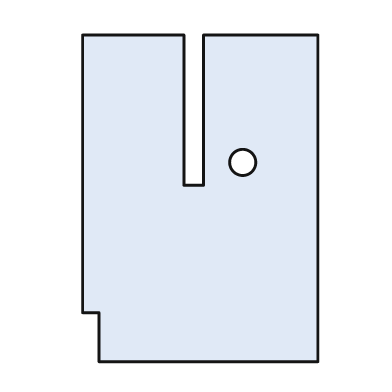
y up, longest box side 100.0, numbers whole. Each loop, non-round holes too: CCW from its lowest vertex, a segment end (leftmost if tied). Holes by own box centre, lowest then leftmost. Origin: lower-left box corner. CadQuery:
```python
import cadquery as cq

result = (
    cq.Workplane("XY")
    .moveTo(5.0, 0.0)
    .lineTo(72.0, 0.0)
    .lineTo(72.0, 100.0)
    .lineTo(37.0, 100.0)
    .lineTo(37.0, 54.0)
    .lineTo(31.0, 54.0)
    .lineTo(31.0, 100.0)
    .lineTo(0.0, 100.0)
    .lineTo(0.0, 15.0)
    .lineTo(5.0, 15.0)
    .close()
    .moveTo(49.0, 61.0)
    .circle(4.0)
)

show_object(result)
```